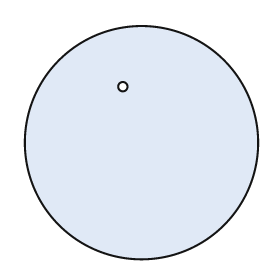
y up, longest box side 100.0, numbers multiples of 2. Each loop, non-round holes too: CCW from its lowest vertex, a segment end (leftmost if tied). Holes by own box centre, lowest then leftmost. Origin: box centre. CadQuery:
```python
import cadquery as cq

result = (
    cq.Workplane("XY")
    .moveTo(0.0, 0.0)
    .circle(50.0)
    .moveTo(-8.0, 24.0)
    .circle(2.0)
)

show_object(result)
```